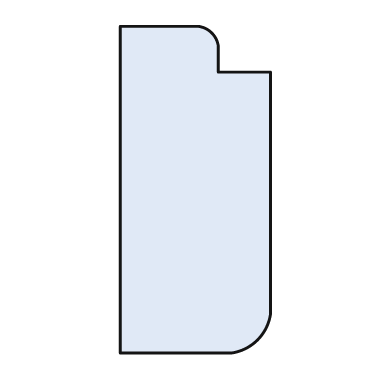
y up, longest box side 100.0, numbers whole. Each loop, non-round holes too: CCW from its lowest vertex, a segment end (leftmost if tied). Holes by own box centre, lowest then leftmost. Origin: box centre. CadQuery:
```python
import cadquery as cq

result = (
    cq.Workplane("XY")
    .moveTo(-23.0, -50.0)
    .lineTo(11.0, -50.0)
    .threePointArc((19.0, -46.0), (23.0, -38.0))
    .lineTo(23.0, 36.0)
    .lineTo(7.0, 36.0)
    .lineTo(7.0, 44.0)
    .threePointArc((5.0, 48.0), (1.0, 50.0))
    .lineTo(-23.0, 50.0)
    .close()
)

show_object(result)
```